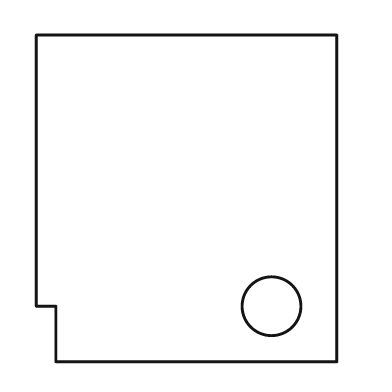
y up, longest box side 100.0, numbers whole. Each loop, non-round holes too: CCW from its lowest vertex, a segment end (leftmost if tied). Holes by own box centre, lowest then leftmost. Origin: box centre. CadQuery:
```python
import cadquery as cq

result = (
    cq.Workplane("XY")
    .moveTo(-40.0, -50.0)
    .lineTo(46.0, -50.0)
    .lineTo(46.0, 50.0)
    .lineTo(-46.0, 50.0)
    .lineTo(-46.0, -33.0)
    .lineTo(-40.0, -33.0)
    .close()
    .moveTo(26.0, -33.0)
    .circle(9.0)
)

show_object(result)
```